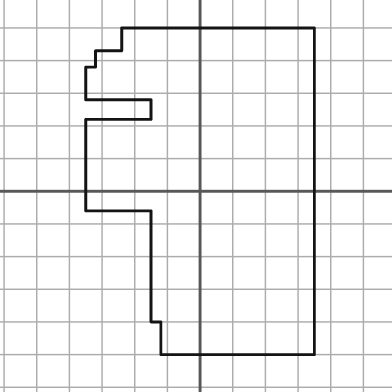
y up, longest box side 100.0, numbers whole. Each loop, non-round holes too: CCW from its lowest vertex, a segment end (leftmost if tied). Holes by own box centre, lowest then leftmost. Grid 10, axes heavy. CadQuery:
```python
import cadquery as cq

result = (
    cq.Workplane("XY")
    .moveTo(-12.0, -50.0)
    .lineTo(35.0, -50.0)
    .lineTo(35.0, 50.0)
    .lineTo(-24.0, 50.0)
    .lineTo(-24.0, 43.0)
    .lineTo(-32.0, 43.0)
    .lineTo(-32.0, 38.0)
    .lineTo(-35.0, 38.0)
    .lineTo(-35.0, 28.0)
    .lineTo(-15.0, 28.0)
    .lineTo(-15.0, 22.0)
    .lineTo(-35.0, 22.0)
    .lineTo(-35.0, -6.0)
    .lineTo(-15.0, -6.0)
    .lineTo(-15.0, -40.0)
    .lineTo(-12.0, -40.0)
    .close()
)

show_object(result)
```